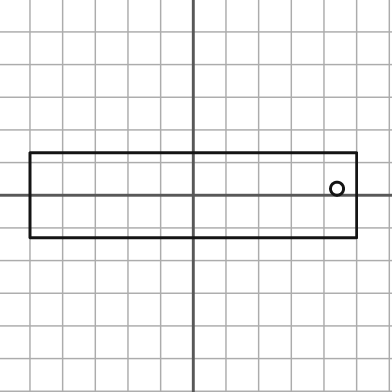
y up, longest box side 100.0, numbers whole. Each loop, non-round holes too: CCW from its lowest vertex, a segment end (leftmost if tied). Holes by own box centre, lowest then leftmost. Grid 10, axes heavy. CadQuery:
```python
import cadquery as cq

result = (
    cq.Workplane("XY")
    .moveTo(-50.0, -13.0)
    .lineTo(50.0, -13.0)
    .lineTo(50.0, 13.0)
    .lineTo(-50.0, 13.0)
    .close()
    .moveTo(44.0, 2.0)
    .circle(2.0)
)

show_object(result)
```